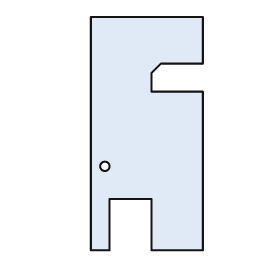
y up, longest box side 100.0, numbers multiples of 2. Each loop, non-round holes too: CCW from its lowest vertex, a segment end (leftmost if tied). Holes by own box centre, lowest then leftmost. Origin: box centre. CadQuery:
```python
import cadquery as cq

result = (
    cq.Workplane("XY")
    .moveTo(-24.0, -50.0)
    .lineTo(-16.0, -50.0)
    .lineTo(-16.0, -28.0)
    .lineTo(2.0, -28.0)
    .lineTo(2.0, -50.0)
    .lineTo(24.0, -50.0)
    .lineTo(24.0, 18.0)
    .lineTo(2.0, 18.0)
    .lineTo(2.0, 26.0)
    .lineTo(6.0, 30.0)
    .lineTo(24.0, 30.0)
    .lineTo(24.0, 50.0)
    .lineTo(-24.0, 50.0)
    .close()
    .moveTo(-18.0, -14.0)
    .circle(2.0)
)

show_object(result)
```